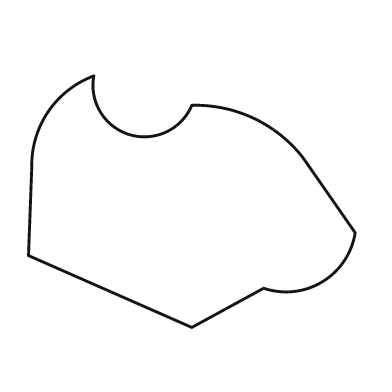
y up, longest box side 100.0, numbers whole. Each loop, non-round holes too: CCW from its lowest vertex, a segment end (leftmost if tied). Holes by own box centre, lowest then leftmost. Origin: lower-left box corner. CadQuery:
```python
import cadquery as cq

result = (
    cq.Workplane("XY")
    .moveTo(50.0, 0.0)
    .lineTo(72.0, 12.0)
    .threePointArc((90.0, 14.0), (100.0, 29.0))
    .lineTo(84.0, 52.0)
    .threePointArc((69.0, 64.0), (50.0, 68.0))
    .threePointArc((31.0, 59.0), (20.0, 77.0))
    .threePointArc((6.0, 66.0), (1.0, 49.0))
    .lineTo(0.0, 22.0)
    .close()
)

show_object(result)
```